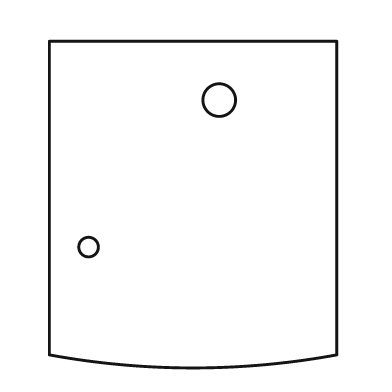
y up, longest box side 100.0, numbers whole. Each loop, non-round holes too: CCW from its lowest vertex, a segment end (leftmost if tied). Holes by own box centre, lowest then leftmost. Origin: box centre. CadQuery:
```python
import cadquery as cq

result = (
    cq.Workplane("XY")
    .moveTo(-44.0, -46.0)
    .threePointArc((0.0, -50.0), (44.0, -46.0))
    .lineTo(44.0, 50.0)
    .lineTo(-44.0, 50.0)
    .close()
    .moveTo(-32.0, -13.0)
    .circle(3.0)
    .moveTo(8.0, 32.0)
    .circle(5.0)
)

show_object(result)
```